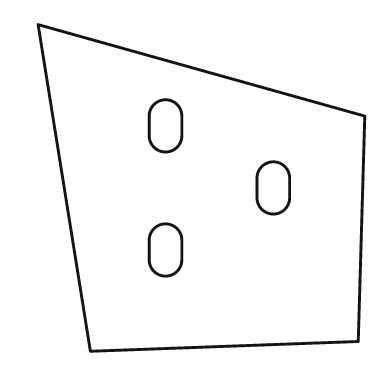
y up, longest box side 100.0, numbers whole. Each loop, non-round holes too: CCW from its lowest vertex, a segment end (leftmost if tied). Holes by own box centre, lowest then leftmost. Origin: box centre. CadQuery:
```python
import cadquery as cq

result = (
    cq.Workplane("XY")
    .moveTo(-34.0, -50.0)
    .lineTo(48.0, -47.0)
    .lineTo(50.0, 22.0)
    .lineTo(-50.0, 50.0)
    .close()
    .moveTo(-16.0, -22.0)
    .threePointArc((-11.0, -27.0), (-6.0, -22.0))
    .lineTo(-6.0, -16.0)
    .threePointArc((-11.0, -11.0), (-16.0, -16.0))
    .close()
    .moveTo(17.0, -3.0)
    .threePointArc((22.0, -8.0), (27.0, -3.0))
    .lineTo(27.0, 3.0)
    .threePointArc((22.0, 8.0), (17.0, 3.0))
    .close()
    .moveTo(-16.0, 16.0)
    .threePointArc((-11.0, 11.0), (-6.0, 16.0))
    .lineTo(-6.0, 22.0)
    .threePointArc((-11.0, 27.0), (-16.0, 22.0))
    .close()
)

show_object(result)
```